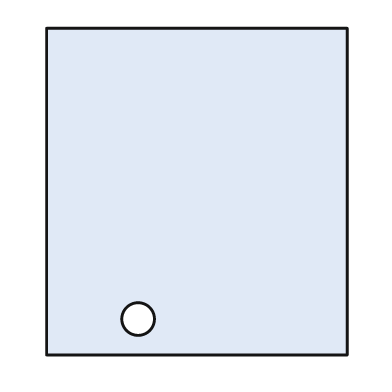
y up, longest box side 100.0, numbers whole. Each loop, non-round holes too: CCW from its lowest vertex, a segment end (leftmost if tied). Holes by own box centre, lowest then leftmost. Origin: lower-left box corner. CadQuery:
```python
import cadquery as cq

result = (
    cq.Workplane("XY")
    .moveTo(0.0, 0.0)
    .lineTo(92.0, 0.0)
    .lineTo(92.0, 100.0)
    .lineTo(0.0, 100.0)
    .close()
    .moveTo(28.0, 11.0)
    .circle(5.0)
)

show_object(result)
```